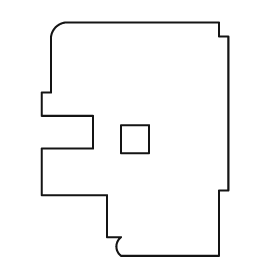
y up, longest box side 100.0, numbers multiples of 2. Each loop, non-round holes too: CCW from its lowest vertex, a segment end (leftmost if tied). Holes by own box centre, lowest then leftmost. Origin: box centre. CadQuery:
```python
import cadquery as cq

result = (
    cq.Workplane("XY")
    .moveTo(-6.0, -50.0)
    .lineTo(36.0, -50.0)
    .lineTo(36.0, -22.0)
    .lineTo(40.0, -22.0)
    .lineTo(40.0, 44.0)
    .lineTo(36.0, 44.0)
    .lineTo(36.0, 50.0)
    .lineTo(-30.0, 50.0)
    .threePointArc((-34.0, 48.0), (-36.0, 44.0))
    .lineTo(-36.0, 20.0)
    .lineTo(-40.0, 20.0)
    .lineTo(-40.0, 10.0)
    .lineTo(-18.0, 10.0)
    .lineTo(-18.0, -4.0)
    .lineTo(-40.0, -4.0)
    .lineTo(-40.0, -24.0)
    .lineTo(-12.0, -24.0)
    .lineTo(-12.0, -42.0)
    .lineTo(-6.0, -42.0)
    .threePointArc((-8.0, -46.0), (-6.0, -50.0))
    .close()
    .moveTo(-6.0, -6.0)
    .lineTo(6.0, -6.0)
    .lineTo(6.0, 6.0)
    .lineTo(-6.0, 6.0)
    .close()
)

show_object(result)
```